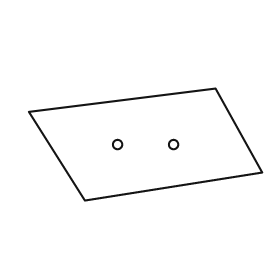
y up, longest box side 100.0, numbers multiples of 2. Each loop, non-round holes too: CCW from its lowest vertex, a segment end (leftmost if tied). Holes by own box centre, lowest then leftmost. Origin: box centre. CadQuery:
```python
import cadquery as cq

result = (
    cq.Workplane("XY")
    .moveTo(-26.0, -24.0)
    .lineTo(50.0, -12.0)
    .lineTo(30.0, 24.0)
    .lineTo(-50.0, 14.0)
    .close()
    .moveTo(-12.0, 0.0)
    .circle(2.0)
    .moveTo(12.0, 0.0)
    .circle(2.0)
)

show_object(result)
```